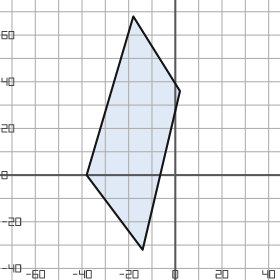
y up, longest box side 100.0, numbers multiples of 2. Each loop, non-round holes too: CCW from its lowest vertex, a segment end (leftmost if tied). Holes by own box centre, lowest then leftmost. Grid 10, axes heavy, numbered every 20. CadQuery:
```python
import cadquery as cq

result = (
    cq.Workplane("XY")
    .moveTo(-14.0, -32.0)
    .lineTo(2.0, 36.0)
    .lineTo(-18.0, 68.0)
    .lineTo(-38.0, 0.0)
    .close()
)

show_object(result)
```